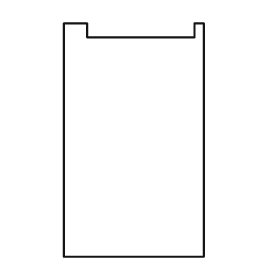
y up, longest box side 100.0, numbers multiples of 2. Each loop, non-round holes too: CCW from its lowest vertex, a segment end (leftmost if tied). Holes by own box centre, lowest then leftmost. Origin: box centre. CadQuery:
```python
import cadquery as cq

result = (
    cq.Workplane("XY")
    .moveTo(-30.0, -50.0)
    .lineTo(30.0, -50.0)
    .lineTo(30.0, 50.0)
    .lineTo(26.0, 50.0)
    .lineTo(26.0, 44.0)
    .lineTo(-20.0, 44.0)
    .lineTo(-20.0, 50.0)
    .lineTo(-30.0, 50.0)
    .close()
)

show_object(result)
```